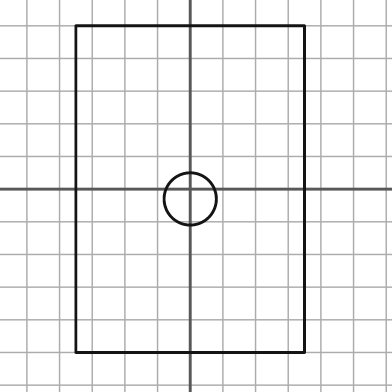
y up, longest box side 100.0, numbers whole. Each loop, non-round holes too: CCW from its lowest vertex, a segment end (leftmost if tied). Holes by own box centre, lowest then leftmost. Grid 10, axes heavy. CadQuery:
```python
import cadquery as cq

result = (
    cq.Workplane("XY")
    .moveTo(-35.0, -50.0)
    .lineTo(35.0, -50.0)
    .lineTo(35.0, 50.0)
    .lineTo(-35.0, 50.0)
    .close()
    .moveTo(0.0, -3.0)
    .circle(8.0)
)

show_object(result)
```